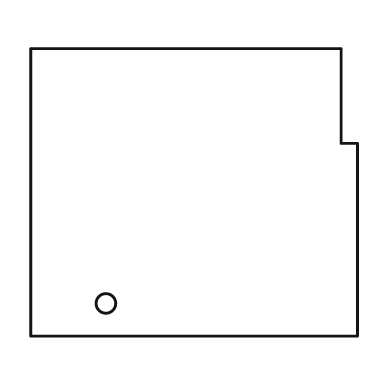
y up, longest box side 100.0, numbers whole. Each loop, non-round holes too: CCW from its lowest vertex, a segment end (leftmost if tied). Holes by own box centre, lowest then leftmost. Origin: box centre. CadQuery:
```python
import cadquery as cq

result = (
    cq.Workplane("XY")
    .moveTo(-50.0, -44.0)
    .lineTo(50.0, -44.0)
    .lineTo(50.0, 15.0)
    .lineTo(45.0, 15.0)
    .lineTo(45.0, 44.0)
    .lineTo(-50.0, 44.0)
    .close()
    .moveTo(-27.0, -34.0)
    .circle(3.0)
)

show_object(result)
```